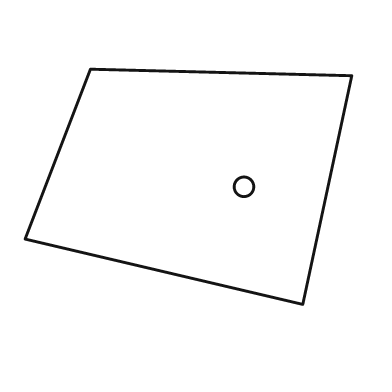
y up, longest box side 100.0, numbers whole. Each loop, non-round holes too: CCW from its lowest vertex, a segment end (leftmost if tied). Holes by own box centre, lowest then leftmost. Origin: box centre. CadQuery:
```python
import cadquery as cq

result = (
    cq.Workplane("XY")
    .moveTo(35.0, -36.0)
    .lineTo(50.0, 34.0)
    .lineTo(-30.0, 36.0)
    .lineTo(-50.0, -16.0)
    .close()
    .moveTo(17.0, 0.0)
    .circle(3.0)
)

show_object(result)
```